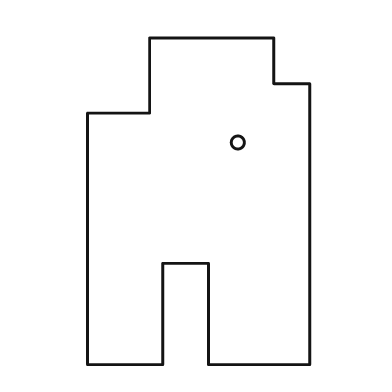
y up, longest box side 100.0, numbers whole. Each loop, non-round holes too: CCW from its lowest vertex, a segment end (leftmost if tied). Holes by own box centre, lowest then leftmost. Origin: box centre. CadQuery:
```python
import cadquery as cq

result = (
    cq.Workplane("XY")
    .moveTo(-34.0, -50.0)
    .lineTo(-11.0, -50.0)
    .lineTo(-11.0, -19.0)
    .lineTo(3.0, -19.0)
    .lineTo(3.0, -50.0)
    .lineTo(34.0, -50.0)
    .lineTo(34.0, 36.0)
    .lineTo(23.0, 36.0)
    .lineTo(23.0, 50.0)
    .lineTo(-15.0, 50.0)
    .lineTo(-15.0, 27.0)
    .lineTo(-34.0, 27.0)
    .close()
    .moveTo(12.0, 18.0)
    .circle(2.0)
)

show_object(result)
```